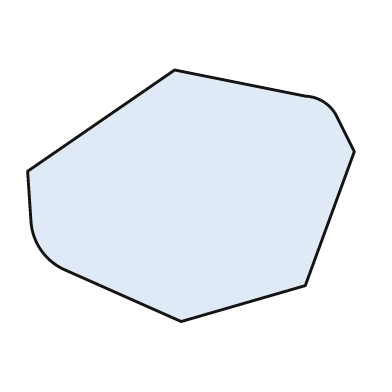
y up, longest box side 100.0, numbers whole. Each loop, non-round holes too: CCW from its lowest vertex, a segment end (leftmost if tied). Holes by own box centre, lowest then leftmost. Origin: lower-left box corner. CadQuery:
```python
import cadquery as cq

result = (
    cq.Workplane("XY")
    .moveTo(47.0, 0.0)
    .lineTo(85.0, 11.0)
    .lineTo(100.0, 52.0)
    .lineTo(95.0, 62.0)
    .threePointArc((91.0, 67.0), (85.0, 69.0))
    .lineTo(45.0, 77.0)
    .lineTo(0.0, 46.0)
    .lineTo(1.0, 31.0)
    .threePointArc((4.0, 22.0), (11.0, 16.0))
    .close()
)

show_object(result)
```